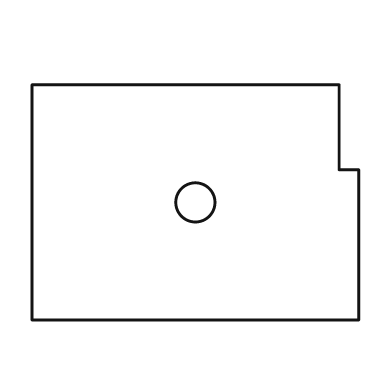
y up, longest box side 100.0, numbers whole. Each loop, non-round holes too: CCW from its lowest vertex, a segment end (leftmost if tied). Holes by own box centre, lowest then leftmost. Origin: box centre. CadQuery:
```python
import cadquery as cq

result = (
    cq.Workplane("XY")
    .moveTo(-50.0, -36.0)
    .lineTo(50.0, -36.0)
    .lineTo(50.0, 10.0)
    .lineTo(44.0, 10.0)
    .lineTo(44.0, 36.0)
    .lineTo(-50.0, 36.0)
    .close()
    .moveTo(0.0, 0.0)
    .circle(6.0)
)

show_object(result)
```